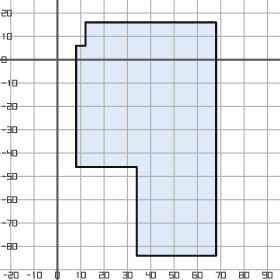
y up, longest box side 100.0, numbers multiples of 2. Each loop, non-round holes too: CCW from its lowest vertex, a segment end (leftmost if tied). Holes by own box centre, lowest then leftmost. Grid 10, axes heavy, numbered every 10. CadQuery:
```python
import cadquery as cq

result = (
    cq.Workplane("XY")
    .moveTo(34.0, -84.0)
    .lineTo(68.0, -84.0)
    .lineTo(68.0, 16.0)
    .lineTo(12.0, 16.0)
    .lineTo(12.0, 6.0)
    .lineTo(8.0, 6.0)
    .lineTo(8.0, -46.0)
    .lineTo(34.0, -46.0)
    .close()
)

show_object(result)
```